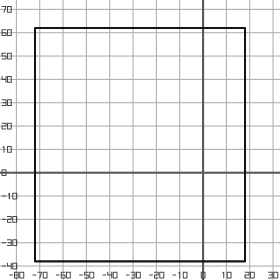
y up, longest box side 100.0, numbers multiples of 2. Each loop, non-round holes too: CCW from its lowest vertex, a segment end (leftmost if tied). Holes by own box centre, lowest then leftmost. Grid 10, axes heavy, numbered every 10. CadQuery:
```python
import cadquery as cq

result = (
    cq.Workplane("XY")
    .moveTo(-72.0, -38.0)
    .lineTo(18.0, -38.0)
    .lineTo(18.0, 62.0)
    .lineTo(-72.0, 62.0)
    .close()
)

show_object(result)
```